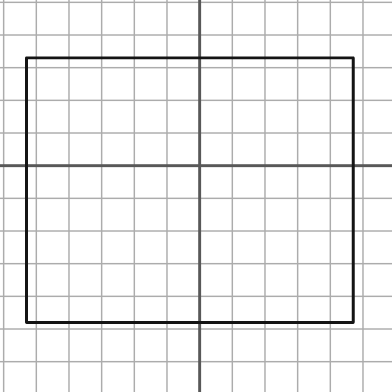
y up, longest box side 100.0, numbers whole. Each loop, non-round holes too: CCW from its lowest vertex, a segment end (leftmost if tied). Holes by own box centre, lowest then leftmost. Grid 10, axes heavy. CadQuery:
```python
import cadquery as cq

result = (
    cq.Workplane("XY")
    .moveTo(-53.0, -48.0)
    .lineTo(47.0, -48.0)
    .lineTo(47.0, 33.0)
    .lineTo(-53.0, 33.0)
    .close()
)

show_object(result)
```